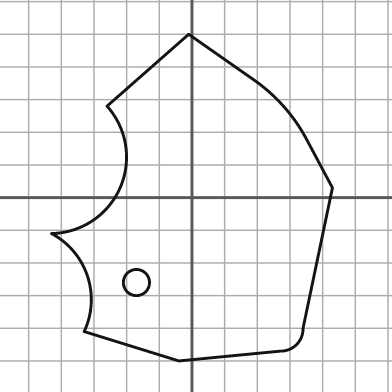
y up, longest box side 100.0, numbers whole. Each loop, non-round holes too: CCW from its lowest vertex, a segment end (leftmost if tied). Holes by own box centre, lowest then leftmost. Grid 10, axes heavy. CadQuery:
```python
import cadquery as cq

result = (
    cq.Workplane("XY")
    .moveTo(-4.0, -50.0)
    .lineTo(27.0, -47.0)
    .threePointArc((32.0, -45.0), (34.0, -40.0))
    .lineTo(43.0, 3.0)
    .lineTo(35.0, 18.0)
    .threePointArc((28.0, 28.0), (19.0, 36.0))
    .lineTo(-1.0, 50.0)
    .lineTo(-26.0, 28.0)
    .threePointArc((-22.0, 3.0), (-43.0, -11.0))
    .threePointArc((-32.0, -24.0), (-33.0, -41.0))
    .close()
    .moveTo(-17.0, -26.0)
    .circle(4.0)
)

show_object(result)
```